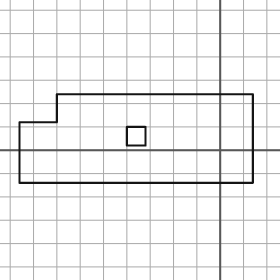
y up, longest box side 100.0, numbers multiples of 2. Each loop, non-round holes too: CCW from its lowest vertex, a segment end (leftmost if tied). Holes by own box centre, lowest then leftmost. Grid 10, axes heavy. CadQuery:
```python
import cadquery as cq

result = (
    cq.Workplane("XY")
    .moveTo(-86.0, -14.0)
    .lineTo(14.0, -14.0)
    .lineTo(14.0, 24.0)
    .lineTo(-70.0, 24.0)
    .lineTo(-70.0, 12.0)
    .lineTo(-86.0, 12.0)
    .close()
    .moveTo(-40.0, 2.0)
    .lineTo(-32.0, 2.0)
    .lineTo(-32.0, 10.0)
    .lineTo(-40.0, 10.0)
    .close()
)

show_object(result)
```